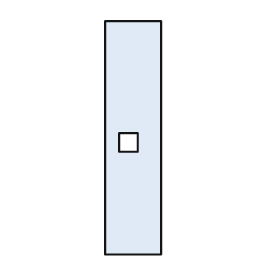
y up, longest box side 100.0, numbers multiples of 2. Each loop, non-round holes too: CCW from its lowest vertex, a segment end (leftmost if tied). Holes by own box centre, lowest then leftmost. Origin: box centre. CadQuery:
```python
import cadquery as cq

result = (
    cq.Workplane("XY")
    .moveTo(-12.0, -50.0)
    .lineTo(12.0, -50.0)
    .lineTo(12.0, 50.0)
    .lineTo(-12.0, 50.0)
    .close()
    .moveTo(-6.0, -6.0)
    .lineTo(2.0, -6.0)
    .lineTo(2.0, 2.0)
    .lineTo(-6.0, 2.0)
    .close()
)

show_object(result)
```